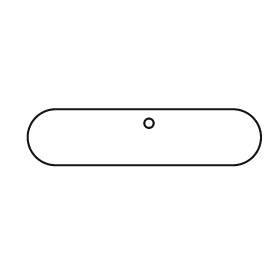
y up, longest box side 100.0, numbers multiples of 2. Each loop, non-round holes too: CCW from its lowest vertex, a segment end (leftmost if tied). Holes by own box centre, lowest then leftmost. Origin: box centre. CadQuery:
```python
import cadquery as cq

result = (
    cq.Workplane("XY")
    .moveTo(-38.0, -12.0)
    .lineTo(38.0, -12.0)
    .threePointArc((50.0, 0.0), (38.0, 12.0))
    .lineTo(-38.0, 12.0)
    .threePointArc((-50.0, 0.0), (-38.0, -12.0))
    .close()
    .moveTo(2.0, 6.0)
    .circle(2.0)
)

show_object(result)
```